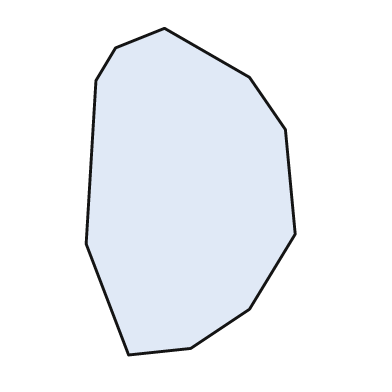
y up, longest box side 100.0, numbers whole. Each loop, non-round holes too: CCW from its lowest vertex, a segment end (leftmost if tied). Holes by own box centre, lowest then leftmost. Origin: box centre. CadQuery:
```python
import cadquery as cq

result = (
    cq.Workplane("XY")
    .moveTo(-19.0, -50.0)
    .lineTo(0.0, -48.0)
    .lineTo(18.0, -36.0)
    .lineTo(32.0, -13.0)
    .lineTo(29.0, 19.0)
    .lineTo(18.0, 35.0)
    .lineTo(-8.0, 50.0)
    .lineTo(-23.0, 44.0)
    .lineTo(-29.0, 34.0)
    .lineTo(-32.0, -16.0)
    .close()
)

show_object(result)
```